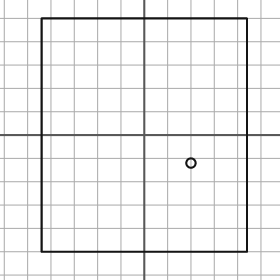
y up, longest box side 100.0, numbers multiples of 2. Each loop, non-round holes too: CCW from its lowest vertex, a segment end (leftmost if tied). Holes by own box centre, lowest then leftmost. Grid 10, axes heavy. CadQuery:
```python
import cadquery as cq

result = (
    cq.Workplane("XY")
    .moveTo(-44.0, -50.0)
    .lineTo(44.0, -50.0)
    .lineTo(44.0, 50.0)
    .lineTo(-44.0, 50.0)
    .close()
    .moveTo(20.0, -12.0)
    .circle(2.0)
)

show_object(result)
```